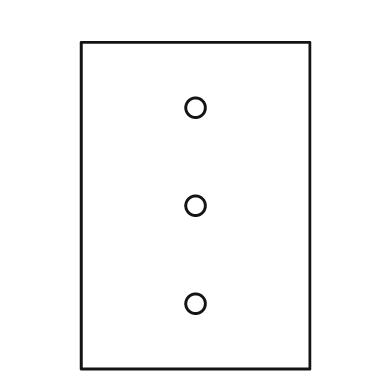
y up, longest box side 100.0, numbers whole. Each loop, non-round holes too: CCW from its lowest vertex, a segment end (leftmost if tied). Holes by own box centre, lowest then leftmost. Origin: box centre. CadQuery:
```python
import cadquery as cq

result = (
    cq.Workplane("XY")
    .moveTo(-35.0, -50.0)
    .lineTo(35.0, -50.0)
    .lineTo(35.0, 50.0)
    .lineTo(-35.0, 50.0)
    .close()
    .moveTo(0.0, -30.0)
    .circle(3.0)
    .moveTo(0.0, 0.0)
    .circle(3.0)
    .moveTo(0.0, 30.0)
    .circle(3.0)
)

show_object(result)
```